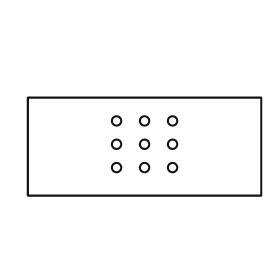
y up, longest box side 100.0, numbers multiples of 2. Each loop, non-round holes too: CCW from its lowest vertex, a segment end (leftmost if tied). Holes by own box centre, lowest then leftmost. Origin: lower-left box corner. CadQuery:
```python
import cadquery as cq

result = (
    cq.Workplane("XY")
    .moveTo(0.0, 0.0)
    .lineTo(100.0, 0.0)
    .lineTo(100.0, 42.0)
    .lineTo(0.0, 42.0)
    .close()
    .moveTo(38.0, 12.0)
    .circle(2.0)
    .moveTo(50.0, 12.0)
    .circle(2.0)
    .moveTo(62.0, 12.0)
    .circle(2.0)
    .moveTo(38.0, 22.0)
    .circle(2.0)
    .moveTo(50.0, 22.0)
    .circle(2.0)
    .moveTo(62.0, 22.0)
    .circle(2.0)
    .moveTo(38.0, 32.0)
    .circle(2.0)
    .moveTo(50.0, 32.0)
    .circle(2.0)
    .moveTo(62.0, 32.0)
    .circle(2.0)
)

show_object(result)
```